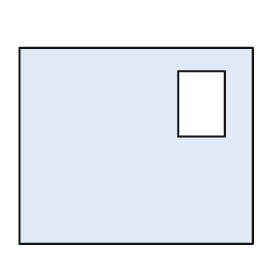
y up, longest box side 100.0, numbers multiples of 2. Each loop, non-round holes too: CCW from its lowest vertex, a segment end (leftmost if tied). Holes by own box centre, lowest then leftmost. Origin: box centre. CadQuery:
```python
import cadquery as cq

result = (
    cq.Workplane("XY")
    .moveTo(-50.0, -42.0)
    .lineTo(50.0, -42.0)
    .lineTo(50.0, 42.0)
    .lineTo(-50.0, 42.0)
    .close()
    .moveTo(18.0, 4.0)
    .lineTo(38.0, 4.0)
    .lineTo(38.0, 32.0)
    .lineTo(18.0, 32.0)
    .close()
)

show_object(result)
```